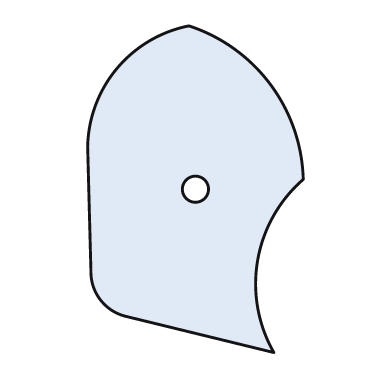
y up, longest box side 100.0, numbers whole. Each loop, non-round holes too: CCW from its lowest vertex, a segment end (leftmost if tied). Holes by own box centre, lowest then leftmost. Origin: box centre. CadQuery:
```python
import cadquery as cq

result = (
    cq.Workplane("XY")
    .moveTo(24.0, -50.0)
    .threePointArc((19.0, -22.0), (33.0, 3.0))
    .threePointArc((23.0, 32.0), (-2.0, 50.0))
    .threePointArc((-24.0, 37.0), (-33.0, 13.0))
    .lineTo(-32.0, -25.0)
    .threePointArc((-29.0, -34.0), (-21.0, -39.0))
    .close()
    .moveTo(0.0, 0.0)
    .circle(4.0)
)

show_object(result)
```